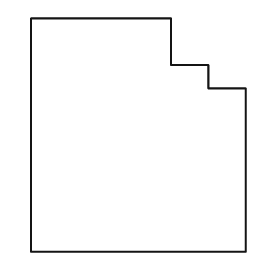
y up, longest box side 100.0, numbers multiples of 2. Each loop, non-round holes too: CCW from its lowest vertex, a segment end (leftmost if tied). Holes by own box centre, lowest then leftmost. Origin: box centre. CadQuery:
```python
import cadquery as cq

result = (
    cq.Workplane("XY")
    .moveTo(-46.0, -50.0)
    .lineTo(46.0, -50.0)
    .lineTo(46.0, 20.0)
    .lineTo(30.0, 20.0)
    .lineTo(30.0, 30.0)
    .lineTo(14.0, 30.0)
    .lineTo(14.0, 50.0)
    .lineTo(-46.0, 50.0)
    .close()
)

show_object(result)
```